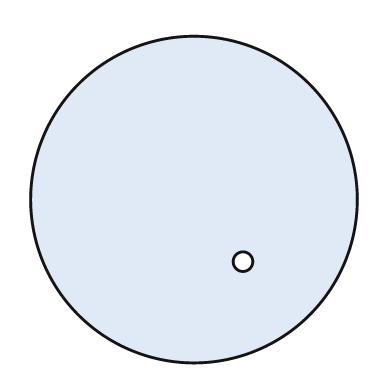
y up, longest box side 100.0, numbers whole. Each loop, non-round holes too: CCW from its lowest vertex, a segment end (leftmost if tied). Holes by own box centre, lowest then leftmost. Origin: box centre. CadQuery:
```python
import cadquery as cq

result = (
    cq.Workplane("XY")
    .moveTo(0.0, 0.0)
    .circle(50.0)
    .moveTo(15.0, -19.0)
    .circle(3.0)
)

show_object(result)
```